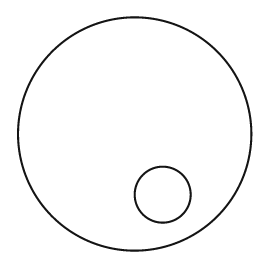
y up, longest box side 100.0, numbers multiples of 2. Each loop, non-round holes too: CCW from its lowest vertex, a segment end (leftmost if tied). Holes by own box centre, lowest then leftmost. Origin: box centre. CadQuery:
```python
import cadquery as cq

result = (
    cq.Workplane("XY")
    .moveTo(0.0, 0.0)
    .circle(50.0)
    .moveTo(12.0, -26.0)
    .circle(12.0)
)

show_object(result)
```